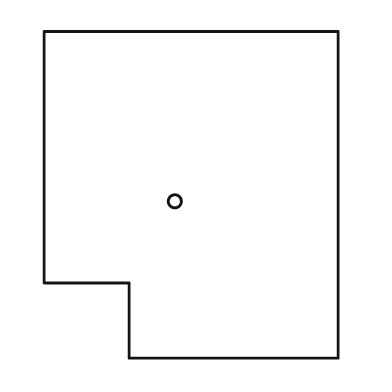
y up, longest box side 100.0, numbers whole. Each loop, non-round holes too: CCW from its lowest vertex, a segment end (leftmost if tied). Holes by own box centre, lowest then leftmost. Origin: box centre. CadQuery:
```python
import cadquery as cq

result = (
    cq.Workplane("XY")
    .moveTo(-19.0, -50.0)
    .lineTo(45.0, -50.0)
    .lineTo(45.0, 50.0)
    .lineTo(-45.0, 50.0)
    .lineTo(-45.0, -27.0)
    .lineTo(-19.0, -27.0)
    .close()
    .moveTo(-5.0, -2.0)
    .circle(2.0)
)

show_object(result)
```